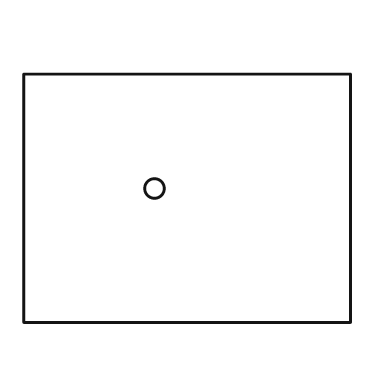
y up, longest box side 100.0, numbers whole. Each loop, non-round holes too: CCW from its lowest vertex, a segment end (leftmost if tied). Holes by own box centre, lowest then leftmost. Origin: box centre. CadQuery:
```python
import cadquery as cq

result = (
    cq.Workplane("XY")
    .moveTo(-50.0, -38.0)
    .lineTo(50.0, -38.0)
    .lineTo(50.0, 38.0)
    .lineTo(-50.0, 38.0)
    .close()
    .moveTo(-10.0, 3.0)
    .circle(3.0)
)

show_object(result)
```